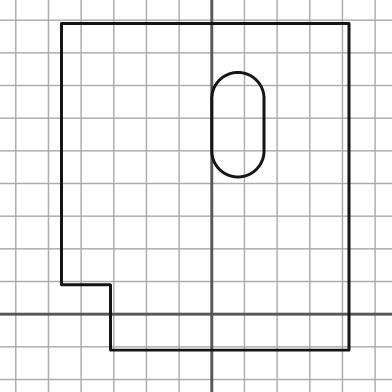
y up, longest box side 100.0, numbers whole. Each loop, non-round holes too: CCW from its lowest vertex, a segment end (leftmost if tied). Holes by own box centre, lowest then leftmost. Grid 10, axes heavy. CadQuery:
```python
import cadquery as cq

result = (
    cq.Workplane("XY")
    .moveTo(-31.0, -11.0)
    .lineTo(42.0, -11.0)
    .lineTo(42.0, 89.0)
    .lineTo(-46.0, 89.0)
    .lineTo(-46.0, 9.0)
    .lineTo(-31.0, 9.0)
    .close()
    .moveTo(0.0, 50.0)
    .threePointArc((8.0, 42.0), (16.0, 50.0))
    .lineTo(16.0, 66.0)
    .threePointArc((8.0, 74.0), (0.0, 66.0))
    .close()
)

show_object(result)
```